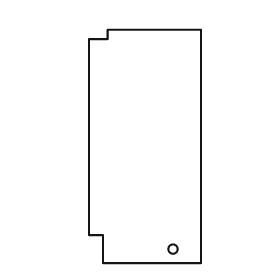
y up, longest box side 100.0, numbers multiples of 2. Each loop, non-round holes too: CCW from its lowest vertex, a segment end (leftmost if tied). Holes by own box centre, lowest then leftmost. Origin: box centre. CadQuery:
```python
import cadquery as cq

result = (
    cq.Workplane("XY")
    .moveTo(-18.0, -50.0)
    .lineTo(24.0, -50.0)
    .lineTo(24.0, 50.0)
    .lineTo(-16.0, 50.0)
    .lineTo(-16.0, 46.0)
    .lineTo(-24.0, 46.0)
    .lineTo(-24.0, -38.0)
    .lineTo(-18.0, -38.0)
    .close()
    .moveTo(12.0, -44.0)
    .circle(2.0)
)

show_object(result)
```